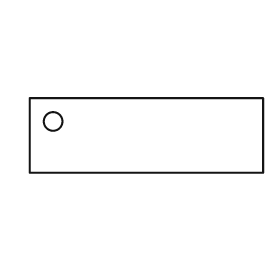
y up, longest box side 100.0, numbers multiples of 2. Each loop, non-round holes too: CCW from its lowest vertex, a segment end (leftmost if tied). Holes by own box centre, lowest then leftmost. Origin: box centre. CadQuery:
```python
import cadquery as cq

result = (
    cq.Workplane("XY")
    .moveTo(-50.0, -16.0)
    .lineTo(50.0, -16.0)
    .lineTo(50.0, 16.0)
    .lineTo(-50.0, 16.0)
    .close()
    .moveTo(-40.0, 6.0)
    .circle(4.0)
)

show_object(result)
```